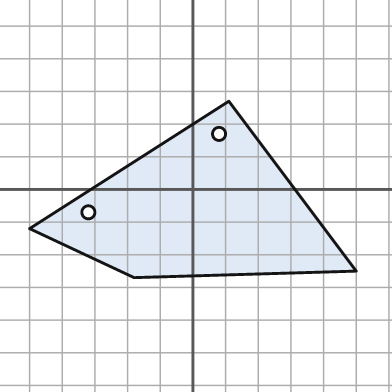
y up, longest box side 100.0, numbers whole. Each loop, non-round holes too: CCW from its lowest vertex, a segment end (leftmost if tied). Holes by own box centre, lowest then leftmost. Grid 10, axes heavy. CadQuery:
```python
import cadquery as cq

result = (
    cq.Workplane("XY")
    .moveTo(-18.0, -27.0)
    .lineTo(50.0, -25.0)
    .lineTo(11.0, 27.0)
    .lineTo(-50.0, -12.0)
    .close()
    .moveTo(-32.0, -7.0)
    .circle(2.0)
    .moveTo(8.0, 17.0)
    .circle(2.0)
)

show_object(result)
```